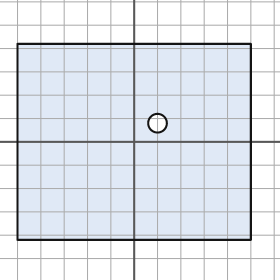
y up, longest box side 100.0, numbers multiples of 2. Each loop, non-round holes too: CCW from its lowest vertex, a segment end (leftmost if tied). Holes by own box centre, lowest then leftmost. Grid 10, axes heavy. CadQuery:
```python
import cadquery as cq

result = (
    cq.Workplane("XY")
    .moveTo(-50.0, -42.0)
    .lineTo(50.0, -42.0)
    .lineTo(50.0, 42.0)
    .lineTo(-50.0, 42.0)
    .close()
    .moveTo(10.0, 8.0)
    .circle(4.0)
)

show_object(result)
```